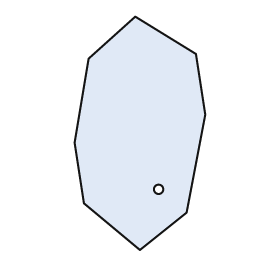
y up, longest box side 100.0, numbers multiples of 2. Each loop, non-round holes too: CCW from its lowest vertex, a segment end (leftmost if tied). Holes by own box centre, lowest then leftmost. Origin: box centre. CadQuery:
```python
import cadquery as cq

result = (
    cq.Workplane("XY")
    .moveTo(0.0, -50.0)
    .lineTo(20.0, -34.0)
    .lineTo(28.0, 8.0)
    .lineTo(24.0, 34.0)
    .lineTo(-2.0, 50.0)
    .lineTo(-22.0, 32.0)
    .lineTo(-28.0, -4.0)
    .lineTo(-24.0, -30.0)
    .close()
    .moveTo(8.0, -24.0)
    .circle(2.0)
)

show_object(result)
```